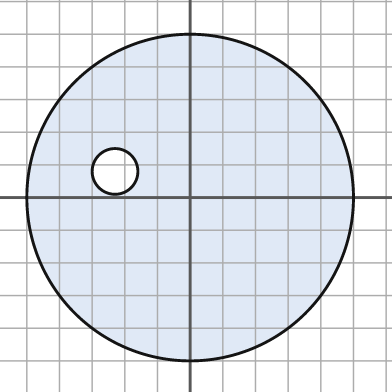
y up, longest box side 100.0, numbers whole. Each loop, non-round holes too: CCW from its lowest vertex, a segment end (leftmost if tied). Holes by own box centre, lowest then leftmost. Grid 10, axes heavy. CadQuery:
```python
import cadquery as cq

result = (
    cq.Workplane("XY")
    .moveTo(0.0, 0.0)
    .circle(50.0)
    .moveTo(-23.0, 8.0)
    .circle(7.0)
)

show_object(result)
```